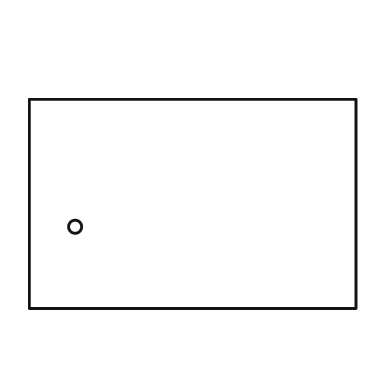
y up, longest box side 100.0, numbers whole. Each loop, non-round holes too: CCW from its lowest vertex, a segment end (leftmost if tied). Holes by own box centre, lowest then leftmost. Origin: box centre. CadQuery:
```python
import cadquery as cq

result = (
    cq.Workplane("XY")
    .moveTo(-50.0, -32.0)
    .lineTo(50.0, -32.0)
    .lineTo(50.0, 32.0)
    .lineTo(-50.0, 32.0)
    .close()
    .moveTo(-36.0, -7.0)
    .circle(2.0)
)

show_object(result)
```